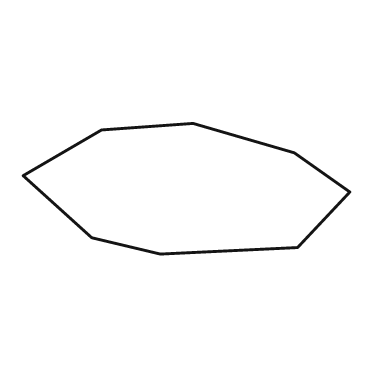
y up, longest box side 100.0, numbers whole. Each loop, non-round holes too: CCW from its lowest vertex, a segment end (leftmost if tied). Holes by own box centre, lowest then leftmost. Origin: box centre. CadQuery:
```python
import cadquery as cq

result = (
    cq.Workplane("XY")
    .moveTo(-8.0, -20.0)
    .lineTo(34.0, -18.0)
    .lineTo(50.0, -1.0)
    .lineTo(33.0, 11.0)
    .lineTo(2.0, 20.0)
    .lineTo(-26.0, 18.0)
    .lineTo(-50.0, 4.0)
    .lineTo(-29.0, -15.0)
    .close()
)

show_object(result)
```